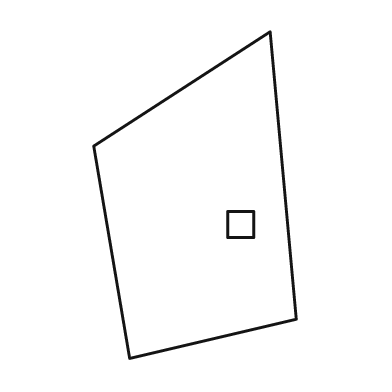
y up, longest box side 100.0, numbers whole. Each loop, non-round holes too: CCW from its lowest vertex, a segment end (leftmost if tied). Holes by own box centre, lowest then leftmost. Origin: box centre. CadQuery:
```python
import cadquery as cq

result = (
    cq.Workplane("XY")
    .moveTo(-20.0, -50.0)
    .lineTo(31.0, -38.0)
    .lineTo(23.0, 50.0)
    .lineTo(-31.0, 15.0)
    .close()
    .moveTo(10.0, -13.0)
    .lineTo(18.0, -13.0)
    .lineTo(18.0, -5.0)
    .lineTo(10.0, -5.0)
    .close()
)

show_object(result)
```